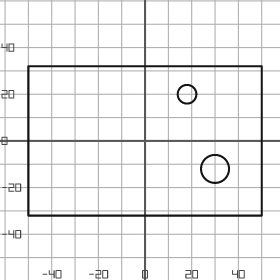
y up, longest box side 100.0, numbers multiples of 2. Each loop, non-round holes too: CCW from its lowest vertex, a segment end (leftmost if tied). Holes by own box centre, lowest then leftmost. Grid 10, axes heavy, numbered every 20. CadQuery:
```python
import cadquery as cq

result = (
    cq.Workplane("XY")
    .moveTo(-50.0, -32.0)
    .lineTo(50.0, -32.0)
    .lineTo(50.0, 32.0)
    .lineTo(-50.0, 32.0)
    .close()
    .moveTo(30.0, -12.0)
    .circle(6.0)
    .moveTo(18.0, 20.0)
    .circle(4.0)
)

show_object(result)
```